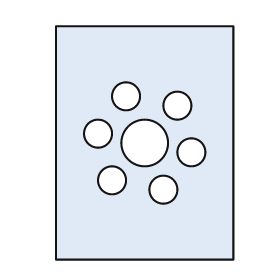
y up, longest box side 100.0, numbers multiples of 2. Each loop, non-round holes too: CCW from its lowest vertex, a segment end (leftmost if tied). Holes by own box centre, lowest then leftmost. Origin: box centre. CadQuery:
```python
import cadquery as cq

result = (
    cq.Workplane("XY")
    .moveTo(-38.0, -50.0)
    .lineTo(38.0, -50.0)
    .lineTo(38.0, 50.0)
    .lineTo(-38.0, 50.0)
    .close()
    .moveTo(8.0, -20.0)
    .circle(6.0)
    .moveTo(-14.0, -16.0)
    .circle(6.0)
    .moveTo(20.0, -4.0)
    .circle(6.0)
    .moveTo(0.0, 0.0)
    .circle(10.0)
    .moveTo(-20.0, 4.0)
    .circle(6.0)
    .moveTo(14.0, 16.0)
    .circle(6.0)
    .moveTo(-8.0, 20.0)
    .circle(6.0)
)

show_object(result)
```